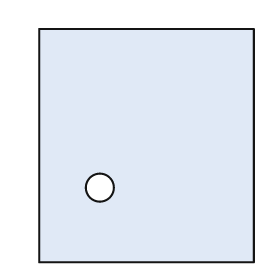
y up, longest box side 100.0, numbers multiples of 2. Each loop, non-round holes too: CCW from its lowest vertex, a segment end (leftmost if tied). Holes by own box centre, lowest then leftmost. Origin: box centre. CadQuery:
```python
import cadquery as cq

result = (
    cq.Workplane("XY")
    .moveTo(-46.0, -50.0)
    .lineTo(46.0, -50.0)
    .lineTo(46.0, 50.0)
    .lineTo(-46.0, 50.0)
    .close()
    .moveTo(-20.0, -18.0)
    .circle(6.0)
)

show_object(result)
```